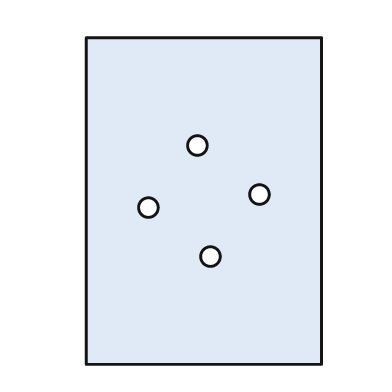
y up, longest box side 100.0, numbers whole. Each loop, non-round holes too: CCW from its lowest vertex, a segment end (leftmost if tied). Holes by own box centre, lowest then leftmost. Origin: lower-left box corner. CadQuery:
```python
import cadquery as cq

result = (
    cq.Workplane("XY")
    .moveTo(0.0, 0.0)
    .lineTo(72.0, 0.0)
    .lineTo(72.0, 100.0)
    .lineTo(0.0, 100.0)
    .close()
    .moveTo(38.0, 33.0)
    .circle(3.0)
    .moveTo(19.0, 48.0)
    .circle(3.0)
    .moveTo(53.0, 52.0)
    .circle(3.0)
    .moveTo(34.0, 67.0)
    .circle(3.0)
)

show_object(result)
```